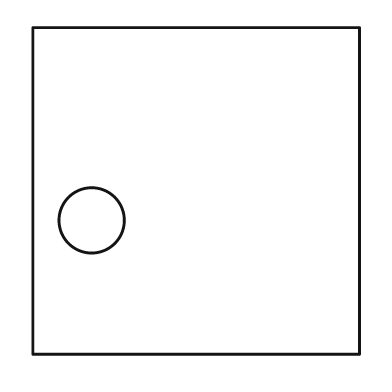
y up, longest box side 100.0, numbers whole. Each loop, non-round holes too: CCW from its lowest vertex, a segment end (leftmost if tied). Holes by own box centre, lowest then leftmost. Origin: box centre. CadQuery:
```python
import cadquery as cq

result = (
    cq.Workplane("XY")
    .moveTo(-50.0, -50.0)
    .lineTo(50.0, -50.0)
    .lineTo(50.0, 50.0)
    .lineTo(-50.0, 50.0)
    .close()
    .moveTo(-32.0, -9.0)
    .circle(10.0)
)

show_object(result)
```